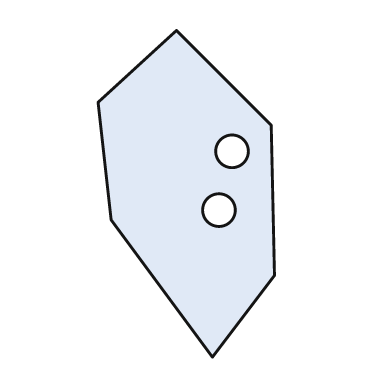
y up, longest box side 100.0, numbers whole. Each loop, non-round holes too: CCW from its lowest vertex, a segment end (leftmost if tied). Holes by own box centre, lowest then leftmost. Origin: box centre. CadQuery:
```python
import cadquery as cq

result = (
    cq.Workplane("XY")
    .moveTo(8.0, -50.0)
    .lineTo(27.0, -25.0)
    .lineTo(26.0, 21.0)
    .lineTo(-3.0, 50.0)
    .lineTo(-27.0, 28.0)
    .lineTo(-23.0, -8.0)
    .close()
    .moveTo(10.0, -5.0)
    .circle(5.0)
    .moveTo(14.0, 13.0)
    .circle(5.0)
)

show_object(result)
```